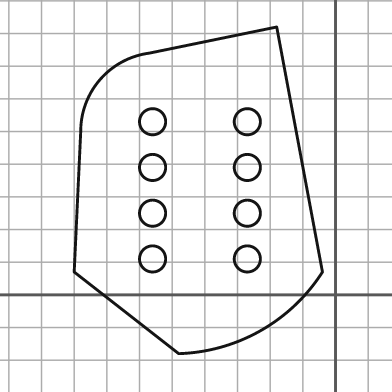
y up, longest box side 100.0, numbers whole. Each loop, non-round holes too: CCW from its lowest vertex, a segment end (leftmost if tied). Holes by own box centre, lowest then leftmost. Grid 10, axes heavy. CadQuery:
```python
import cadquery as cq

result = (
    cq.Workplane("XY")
    .moveTo(-48.0, -18.0)
    .threePointArc((-23.0, -11.0), (-4.0, 7.0))
    .lineTo(-18.0, 82.0)
    .lineTo(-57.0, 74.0)
    .threePointArc((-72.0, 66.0), (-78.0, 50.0))
    .lineTo(-80.0, 7.0)
    .close()
    .moveTo(-56.0, 11.0)
    .circle(4.0)
    .moveTo(-27.0, 11.0)
    .circle(4.0)
    .moveTo(-56.0, 25.0)
    .circle(4.0)
    .moveTo(-27.0, 25.0)
    .circle(4.0)
    .moveTo(-56.0, 39.0)
    .circle(4.0)
    .moveTo(-27.0, 39.0)
    .circle(4.0)
    .moveTo(-56.0, 53.0)
    .circle(4.0)
    .moveTo(-27.0, 53.0)
    .circle(4.0)
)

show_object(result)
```